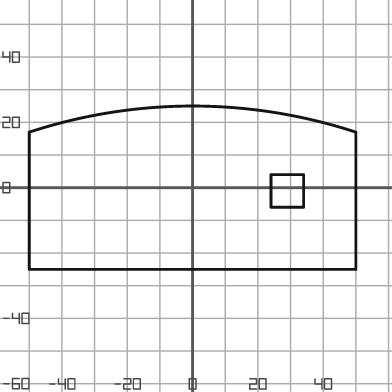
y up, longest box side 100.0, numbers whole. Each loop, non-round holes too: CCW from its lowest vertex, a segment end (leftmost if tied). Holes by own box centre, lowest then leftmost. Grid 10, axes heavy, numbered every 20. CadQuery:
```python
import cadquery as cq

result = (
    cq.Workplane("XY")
    .moveTo(-50.0, -25.0)
    .lineTo(50.0, -25.0)
    .lineTo(50.0, 17.0)
    .threePointArc((0.0, 25.0), (-50.0, 17.0))
    .close()
    .moveTo(24.0, -6.0)
    .lineTo(34.0, -6.0)
    .lineTo(34.0, 4.0)
    .lineTo(24.0, 4.0)
    .close()
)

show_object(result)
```